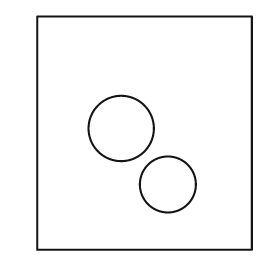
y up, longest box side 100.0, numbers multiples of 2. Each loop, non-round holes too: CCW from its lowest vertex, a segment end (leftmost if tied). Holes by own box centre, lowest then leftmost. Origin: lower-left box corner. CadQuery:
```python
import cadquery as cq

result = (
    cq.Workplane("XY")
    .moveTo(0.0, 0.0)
    .lineTo(92.0, 0.0)
    .lineTo(92.0, 100.0)
    .lineTo(0.0, 100.0)
    .close()
    .moveTo(56.0, 28.0)
    .circle(12.0)
    .moveTo(36.0, 52.0)
    .circle(14.0)
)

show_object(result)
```